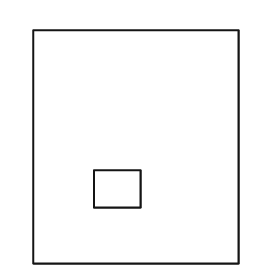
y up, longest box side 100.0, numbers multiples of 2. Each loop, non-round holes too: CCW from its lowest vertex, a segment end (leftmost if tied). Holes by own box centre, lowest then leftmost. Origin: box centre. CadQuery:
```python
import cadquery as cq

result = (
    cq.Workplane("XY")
    .moveTo(-44.0, -50.0)
    .lineTo(44.0, -50.0)
    .lineTo(44.0, 50.0)
    .lineTo(-44.0, 50.0)
    .close()
    .moveTo(-18.0, -26.0)
    .lineTo(2.0, -26.0)
    .lineTo(2.0, -10.0)
    .lineTo(-18.0, -10.0)
    .close()
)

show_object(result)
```